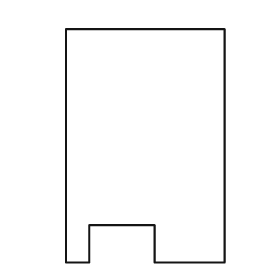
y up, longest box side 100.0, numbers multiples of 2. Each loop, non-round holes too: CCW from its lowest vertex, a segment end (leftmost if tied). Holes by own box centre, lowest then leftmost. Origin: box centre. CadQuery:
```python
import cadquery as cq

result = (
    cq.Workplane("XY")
    .moveTo(-34.0, -50.0)
    .lineTo(-24.0, -50.0)
    .lineTo(-24.0, -34.0)
    .lineTo(4.0, -34.0)
    .lineTo(4.0, -50.0)
    .lineTo(34.0, -50.0)
    .lineTo(34.0, 50.0)
    .lineTo(-34.0, 50.0)
    .close()
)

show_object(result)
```